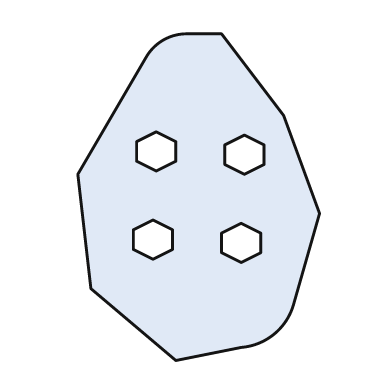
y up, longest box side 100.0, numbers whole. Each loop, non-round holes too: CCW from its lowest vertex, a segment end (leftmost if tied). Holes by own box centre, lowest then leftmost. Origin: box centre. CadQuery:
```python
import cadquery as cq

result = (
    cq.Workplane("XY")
    .moveTo(-7.0, -50.0)
    .lineTo(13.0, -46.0)
    .threePointArc((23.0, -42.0), (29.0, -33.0))
    .lineTo(37.0, -5.0)
    .lineTo(26.0, 25.0)
    .lineTo(7.0, 50.0)
    .lineTo(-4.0, 50.0)
    .threePointArc((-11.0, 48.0), (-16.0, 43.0))
    .lineTo(-37.0, 7.0)
    .lineTo(-33.0, -28.0)
    .close()
    .moveTo(13.0, -20.0)
    .lineTo(19.0, -17.0)
    .lineTo(19.0, -11.0)
    .lineTo(13.0, -8.0)
    .lineTo(7.0, -11.0)
    .lineTo(7.0, -17.0)
    .close()
    .moveTo(-14.0, -19.0)
    .lineTo(-8.0, -16.0)
    .lineTo(-8.0, -10.0)
    .lineTo(-14.0, -7.0)
    .lineTo(-20.0, -10.0)
    .lineTo(-20.0, -16.0)
    .close()
    .moveTo(14.0, 7.0)
    .lineTo(20.0, 10.0)
    .lineTo(20.0, 16.0)
    .lineTo(14.0, 19.0)
    .lineTo(8.0, 16.0)
    .lineTo(8.0, 10.0)
    .close()
    .moveTo(-13.0, 8.0)
    .lineTo(-7.0, 11.0)
    .lineTo(-7.0, 17.0)
    .lineTo(-13.0, 20.0)
    .lineTo(-19.0, 17.0)
    .lineTo(-19.0, 11.0)
    .close()
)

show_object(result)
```